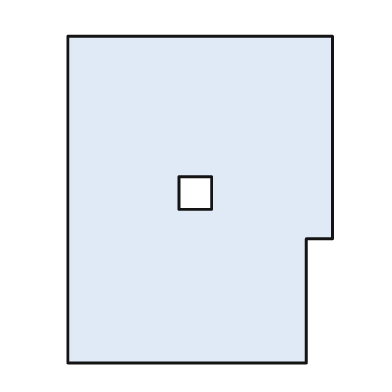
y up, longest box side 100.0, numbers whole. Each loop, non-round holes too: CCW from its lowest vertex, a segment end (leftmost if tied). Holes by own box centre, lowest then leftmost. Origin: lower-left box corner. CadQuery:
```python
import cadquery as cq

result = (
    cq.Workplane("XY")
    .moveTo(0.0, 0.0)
    .lineTo(73.0, 0.0)
    .lineTo(73.0, 38.0)
    .lineTo(81.0, 38.0)
    .lineTo(81.0, 100.0)
    .lineTo(0.0, 100.0)
    .close()
    .moveTo(34.0, 47.0)
    .lineTo(44.0, 47.0)
    .lineTo(44.0, 57.0)
    .lineTo(34.0, 57.0)
    .close()
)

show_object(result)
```